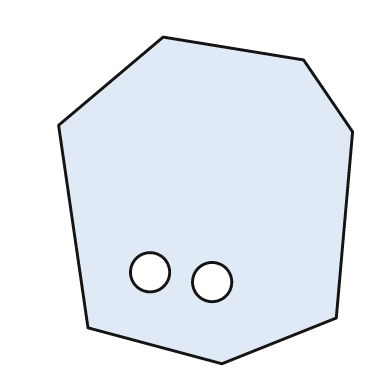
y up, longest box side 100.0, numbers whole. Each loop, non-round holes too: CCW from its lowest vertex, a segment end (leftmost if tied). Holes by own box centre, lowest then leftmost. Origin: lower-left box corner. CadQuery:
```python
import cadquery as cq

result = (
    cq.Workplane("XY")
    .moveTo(50.0, 0.0)
    .lineTo(85.0, 14.0)
    .lineTo(90.0, 71.0)
    .lineTo(75.0, 93.0)
    .lineTo(32.0, 100.0)
    .lineTo(0.0, 73.0)
    .lineTo(9.0, 11.0)
    .close()
    .moveTo(47.0, 25.0)
    .circle(6.0)
    .moveTo(28.0, 28.0)
    .circle(6.0)
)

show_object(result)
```